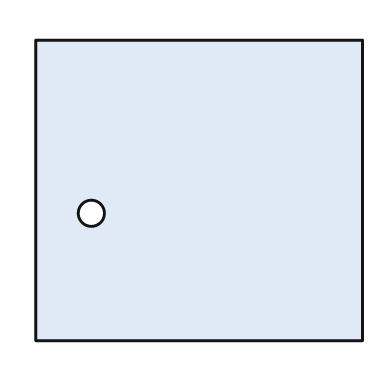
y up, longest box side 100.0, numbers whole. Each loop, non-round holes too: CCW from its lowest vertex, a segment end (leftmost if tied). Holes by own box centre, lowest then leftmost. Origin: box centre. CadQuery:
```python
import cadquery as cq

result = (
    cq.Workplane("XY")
    .moveTo(-50.0, -46.0)
    .lineTo(50.0, -46.0)
    .lineTo(50.0, 46.0)
    .lineTo(-50.0, 46.0)
    .close()
    .moveTo(-33.0, -7.0)
    .circle(4.0)
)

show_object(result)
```